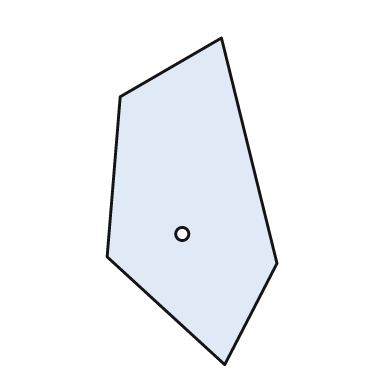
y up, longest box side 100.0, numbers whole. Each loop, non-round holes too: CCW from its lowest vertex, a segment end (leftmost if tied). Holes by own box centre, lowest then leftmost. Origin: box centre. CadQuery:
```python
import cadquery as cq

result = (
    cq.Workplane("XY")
    .moveTo(10.0, -50.0)
    .lineTo(26.0, -19.0)
    .lineTo(9.0, 50.0)
    .lineTo(-22.0, 32.0)
    .lineTo(-26.0, -17.0)
    .close()
    .moveTo(-3.0, -10.0)
    .circle(2.0)
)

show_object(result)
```